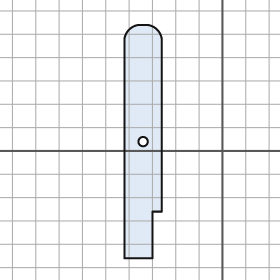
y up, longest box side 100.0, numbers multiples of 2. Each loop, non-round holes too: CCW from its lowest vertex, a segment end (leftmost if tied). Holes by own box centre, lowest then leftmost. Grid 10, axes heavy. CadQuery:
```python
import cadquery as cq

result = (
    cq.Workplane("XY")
    .moveTo(-42.0, -46.0)
    .lineTo(-30.0, -46.0)
    .lineTo(-30.0, -26.0)
    .lineTo(-26.0, -26.0)
    .lineTo(-26.0, 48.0)
    .threePointArc((-28.0, 52.0), (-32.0, 54.0))
    .lineTo(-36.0, 54.0)
    .threePointArc((-40.0, 52.0), (-42.0, 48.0))
    .close()
    .moveTo(-34.0, 4.0)
    .circle(2.0)
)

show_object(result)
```